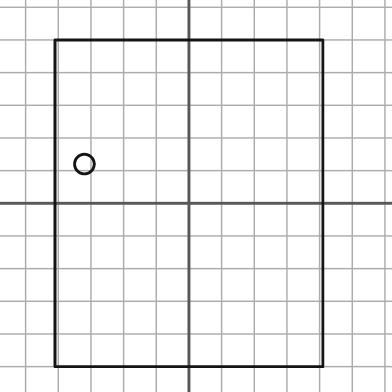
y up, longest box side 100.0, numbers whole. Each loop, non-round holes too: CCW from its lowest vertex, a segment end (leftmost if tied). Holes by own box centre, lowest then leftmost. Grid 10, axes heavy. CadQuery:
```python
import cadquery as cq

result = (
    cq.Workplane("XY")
    .moveTo(-41.0, -50.0)
    .lineTo(41.0, -50.0)
    .lineTo(41.0, 50.0)
    .lineTo(-41.0, 50.0)
    .close()
    .moveTo(-32.0, 12.0)
    .circle(3.0)
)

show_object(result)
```